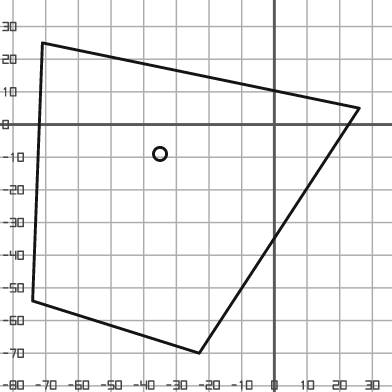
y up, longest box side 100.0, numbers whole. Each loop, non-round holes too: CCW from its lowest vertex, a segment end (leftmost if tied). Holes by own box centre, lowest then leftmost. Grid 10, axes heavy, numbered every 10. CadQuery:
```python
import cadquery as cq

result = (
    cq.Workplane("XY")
    .moveTo(-23.0, -70.0)
    .lineTo(26.0, 5.0)
    .lineTo(-71.0, 25.0)
    .lineTo(-74.0, -54.0)
    .close()
    .moveTo(-35.0, -9.0)
    .circle(2.0)
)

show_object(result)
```